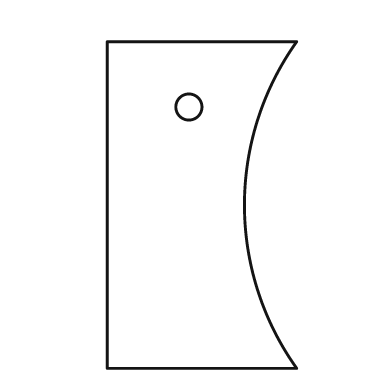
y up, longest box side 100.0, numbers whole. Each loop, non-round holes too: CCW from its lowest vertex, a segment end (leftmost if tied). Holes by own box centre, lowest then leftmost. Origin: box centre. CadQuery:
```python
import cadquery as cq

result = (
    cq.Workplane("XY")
    .moveTo(-29.0, -50.0)
    .lineTo(29.0, -50.0)
    .threePointArc((13.0, 0.0), (29.0, 50.0))
    .lineTo(-29.0, 50.0)
    .close()
    .moveTo(-4.0, 30.0)
    .circle(4.0)
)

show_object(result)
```